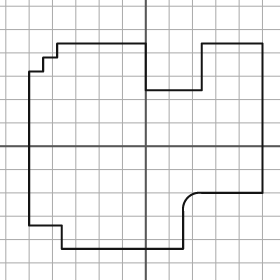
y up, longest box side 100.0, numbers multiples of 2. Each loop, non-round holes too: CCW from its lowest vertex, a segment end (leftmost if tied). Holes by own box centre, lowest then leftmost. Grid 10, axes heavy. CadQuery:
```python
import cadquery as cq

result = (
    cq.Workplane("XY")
    .moveTo(-36.0, -44.0)
    .lineTo(16.0, -44.0)
    .lineTo(16.0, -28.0)
    .threePointArc((18.0, -22.0), (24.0, -20.0))
    .lineTo(50.0, -20.0)
    .lineTo(50.0, 44.0)
    .lineTo(24.0, 44.0)
    .lineTo(24.0, 24.0)
    .lineTo(0.0, 24.0)
    .lineTo(0.0, 44.0)
    .lineTo(-38.0, 44.0)
    .lineTo(-38.0, 38.0)
    .lineTo(-44.0, 38.0)
    .lineTo(-44.0, 32.0)
    .lineTo(-50.0, 32.0)
    .lineTo(-50.0, -34.0)
    .lineTo(-36.0, -34.0)
    .close()
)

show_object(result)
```